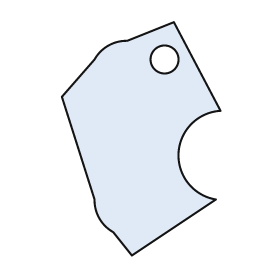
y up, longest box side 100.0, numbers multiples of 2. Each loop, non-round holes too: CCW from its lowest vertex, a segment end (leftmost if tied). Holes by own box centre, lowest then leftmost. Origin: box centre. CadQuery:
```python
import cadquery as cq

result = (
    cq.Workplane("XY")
    .moveTo(-4.0, -50.0)
    .lineTo(32.0, -26.0)
    .threePointArc((16.0, -6.0), (34.0, 12.0))
    .lineTo(14.0, 50.0)
    .lineTo(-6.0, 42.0)
    .threePointArc((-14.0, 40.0), (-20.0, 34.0))
    .lineTo(-34.0, 18.0)
    .lineTo(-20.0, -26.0)
    .threePointArc((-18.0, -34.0), (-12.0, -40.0))
    .close()
    .moveTo(10.0, 34.0)
    .circle(6.0)
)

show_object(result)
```